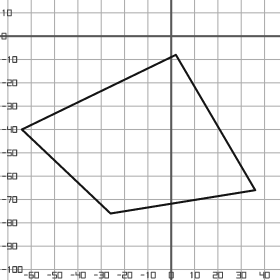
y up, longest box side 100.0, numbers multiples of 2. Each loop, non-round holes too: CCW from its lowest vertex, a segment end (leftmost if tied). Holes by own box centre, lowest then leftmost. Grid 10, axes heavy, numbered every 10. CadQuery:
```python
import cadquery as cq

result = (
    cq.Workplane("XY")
    .moveTo(-26.0, -76.0)
    .lineTo(36.0, -66.0)
    .lineTo(2.0, -8.0)
    .lineTo(-64.0, -40.0)
    .close()
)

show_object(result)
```